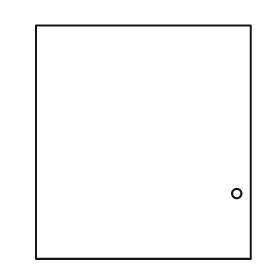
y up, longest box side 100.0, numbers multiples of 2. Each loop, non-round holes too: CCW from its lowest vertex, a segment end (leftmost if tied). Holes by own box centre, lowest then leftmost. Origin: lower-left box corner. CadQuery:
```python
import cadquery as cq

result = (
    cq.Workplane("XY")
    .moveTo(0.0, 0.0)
    .lineTo(92.0, 0.0)
    .lineTo(92.0, 100.0)
    .lineTo(0.0, 100.0)
    .close()
    .moveTo(86.0, 28.0)
    .circle(2.0)
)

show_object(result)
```